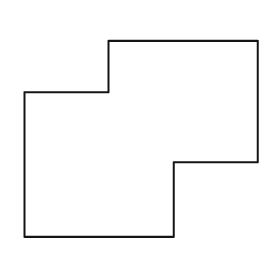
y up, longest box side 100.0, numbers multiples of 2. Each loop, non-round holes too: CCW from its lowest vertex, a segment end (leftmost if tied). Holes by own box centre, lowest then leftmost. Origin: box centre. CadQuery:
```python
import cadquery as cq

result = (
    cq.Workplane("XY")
    .moveTo(-50.0, -42.0)
    .lineTo(14.0, -42.0)
    .lineTo(14.0, -10.0)
    .lineTo(50.0, -10.0)
    .lineTo(50.0, 42.0)
    .lineTo(-14.0, 42.0)
    .lineTo(-14.0, 20.0)
    .lineTo(-50.0, 20.0)
    .close()
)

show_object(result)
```